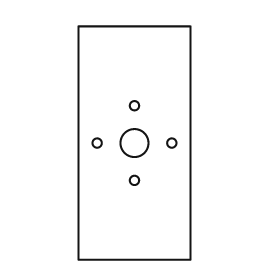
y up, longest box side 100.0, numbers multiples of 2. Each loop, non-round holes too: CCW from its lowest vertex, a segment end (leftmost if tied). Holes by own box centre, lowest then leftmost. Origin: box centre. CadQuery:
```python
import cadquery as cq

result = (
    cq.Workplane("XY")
    .moveTo(-24.0, -50.0)
    .lineTo(24.0, -50.0)
    .lineTo(24.0, 50.0)
    .lineTo(-24.0, 50.0)
    .close()
    .moveTo(0.0, -16.0)
    .circle(2.0)
    .moveTo(-16.0, 0.0)
    .circle(2.0)
    .moveTo(0.0, 0.0)
    .circle(6.0)
    .moveTo(16.0, 0.0)
    .circle(2.0)
    .moveTo(0.0, 16.0)
    .circle(2.0)
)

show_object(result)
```